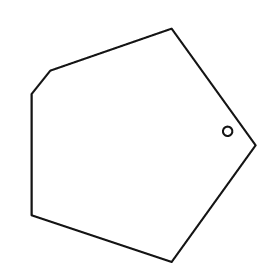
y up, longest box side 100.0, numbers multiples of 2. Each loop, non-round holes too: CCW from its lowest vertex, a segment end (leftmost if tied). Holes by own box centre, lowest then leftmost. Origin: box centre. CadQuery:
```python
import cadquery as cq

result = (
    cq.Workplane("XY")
    .moveTo(12.0, -50.0)
    .lineTo(48.0, 0.0)
    .lineTo(12.0, 50.0)
    .lineTo(-40.0, 32.0)
    .lineTo(-48.0, 22.0)
    .lineTo(-48.0, -30.0)
    .close()
    .moveTo(36.0, 6.0)
    .circle(2.0)
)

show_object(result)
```